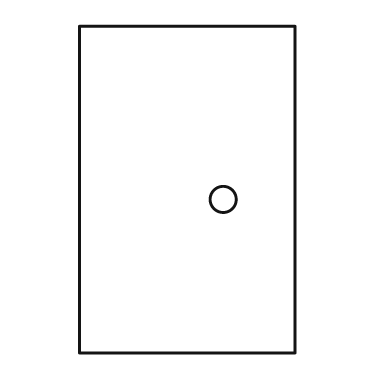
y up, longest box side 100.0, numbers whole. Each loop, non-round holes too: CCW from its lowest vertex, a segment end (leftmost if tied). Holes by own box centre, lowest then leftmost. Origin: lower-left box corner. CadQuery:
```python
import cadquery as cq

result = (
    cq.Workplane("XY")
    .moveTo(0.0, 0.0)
    .lineTo(66.0, 0.0)
    .lineTo(66.0, 100.0)
    .lineTo(0.0, 100.0)
    .close()
    .moveTo(44.0, 47.0)
    .circle(4.0)
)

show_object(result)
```